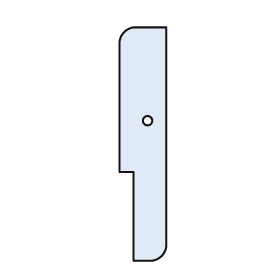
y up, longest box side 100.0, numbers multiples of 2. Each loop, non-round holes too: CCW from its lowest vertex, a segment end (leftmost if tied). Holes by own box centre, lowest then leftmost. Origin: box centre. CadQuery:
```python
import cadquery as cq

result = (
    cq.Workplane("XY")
    .moveTo(-4.0, -50.0)
    .lineTo(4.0, -50.0)
    .threePointArc((8.0, -48.0), (10.0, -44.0))
    .lineTo(10.0, 50.0)
    .lineTo(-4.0, 50.0)
    .threePointArc((-8.0, 48.0), (-10.0, 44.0))
    .lineTo(-10.0, -12.0)
    .lineTo(-4.0, -12.0)
    .close()
    .moveTo(2.0, 10.0)
    .circle(2.0)
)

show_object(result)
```